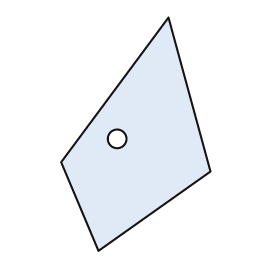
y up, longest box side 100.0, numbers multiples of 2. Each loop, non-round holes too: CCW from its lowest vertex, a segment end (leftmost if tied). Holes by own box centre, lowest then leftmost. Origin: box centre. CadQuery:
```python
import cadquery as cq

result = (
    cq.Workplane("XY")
    .moveTo(-16.0, -50.0)
    .lineTo(32.0, -16.0)
    .lineTo(14.0, 50.0)
    .lineTo(-32.0, -12.0)
    .close()
    .moveTo(-8.0, -2.0)
    .circle(4.0)
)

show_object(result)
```